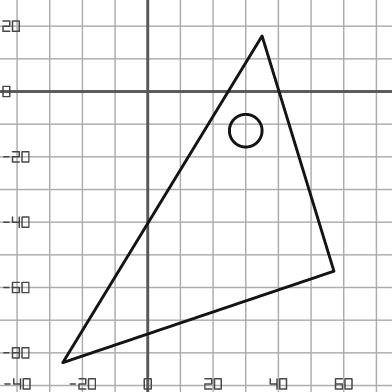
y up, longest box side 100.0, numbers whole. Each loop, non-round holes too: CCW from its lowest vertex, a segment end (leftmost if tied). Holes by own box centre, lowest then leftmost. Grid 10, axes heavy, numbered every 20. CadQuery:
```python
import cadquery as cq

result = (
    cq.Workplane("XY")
    .moveTo(-26.0, -83.0)
    .lineTo(57.0, -55.0)
    .lineTo(35.0, 17.0)
    .close()
    .moveTo(30.0, -12.0)
    .circle(5.0)
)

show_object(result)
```